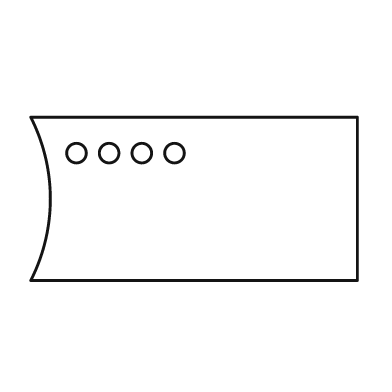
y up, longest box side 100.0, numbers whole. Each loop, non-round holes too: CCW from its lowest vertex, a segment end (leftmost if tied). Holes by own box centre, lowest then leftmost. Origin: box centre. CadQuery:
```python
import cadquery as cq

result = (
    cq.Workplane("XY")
    .moveTo(-50.0, -25.0)
    .lineTo(50.0, -25.0)
    .lineTo(50.0, 25.0)
    .lineTo(-50.0, 25.0)
    .threePointArc((-44.0, 0.0), (-50.0, -25.0))
    .close()
    .moveTo(-36.0, 14.0)
    .circle(3.0)
    .moveTo(-26.0, 14.0)
    .circle(3.0)
    .moveTo(-16.0, 14.0)
    .circle(3.0)
    .moveTo(-6.0, 14.0)
    .circle(3.0)
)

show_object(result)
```